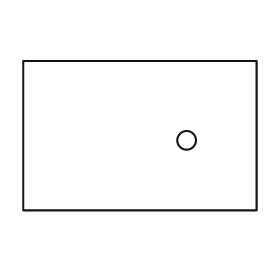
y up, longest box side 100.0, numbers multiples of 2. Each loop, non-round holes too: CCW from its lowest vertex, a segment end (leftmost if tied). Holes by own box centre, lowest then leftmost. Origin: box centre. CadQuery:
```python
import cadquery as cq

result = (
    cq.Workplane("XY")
    .moveTo(-50.0, -32.0)
    .lineTo(50.0, -32.0)
    .lineTo(50.0, 32.0)
    .lineTo(-50.0, 32.0)
    .close()
    .moveTo(20.0, -2.0)
    .circle(4.0)
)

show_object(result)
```